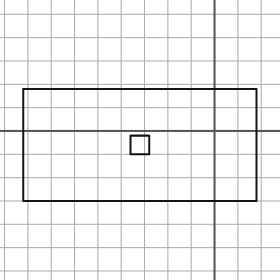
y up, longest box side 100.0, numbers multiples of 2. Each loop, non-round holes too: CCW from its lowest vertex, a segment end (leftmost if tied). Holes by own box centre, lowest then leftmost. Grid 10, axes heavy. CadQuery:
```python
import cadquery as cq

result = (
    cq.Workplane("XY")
    .moveTo(-82.0, -30.0)
    .lineTo(18.0, -30.0)
    .lineTo(18.0, 18.0)
    .lineTo(-82.0, 18.0)
    .close()
    .moveTo(-36.0, -10.0)
    .lineTo(-28.0, -10.0)
    .lineTo(-28.0, -2.0)
    .lineTo(-36.0, -2.0)
    .close()
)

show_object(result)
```